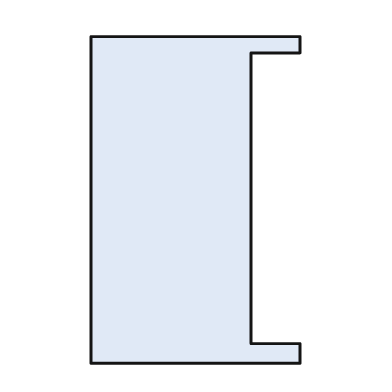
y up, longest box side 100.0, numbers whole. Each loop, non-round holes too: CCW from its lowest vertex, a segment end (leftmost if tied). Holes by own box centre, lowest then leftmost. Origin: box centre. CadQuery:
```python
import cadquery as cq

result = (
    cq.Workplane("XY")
    .moveTo(-32.0, -50.0)
    .lineTo(32.0, -50.0)
    .lineTo(32.0, -44.0)
    .lineTo(17.0, -44.0)
    .lineTo(17.0, 45.0)
    .lineTo(32.0, 45.0)
    .lineTo(32.0, 50.0)
    .lineTo(-32.0, 50.0)
    .close()
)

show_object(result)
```